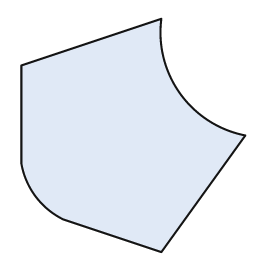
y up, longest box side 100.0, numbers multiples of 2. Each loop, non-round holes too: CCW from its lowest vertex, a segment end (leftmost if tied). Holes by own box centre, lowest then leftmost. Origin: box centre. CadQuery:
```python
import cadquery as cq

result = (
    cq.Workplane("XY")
    .moveTo(12.0, -50.0)
    .lineTo(48.0, 0.0)
    .threePointArc((20.0, 18.0), (12.0, 50.0))
    .lineTo(-48.0, 30.0)
    .lineTo(-48.0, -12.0)
    .threePointArc((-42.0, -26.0), (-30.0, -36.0))
    .close()
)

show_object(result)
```